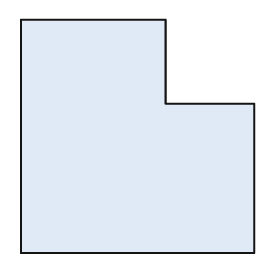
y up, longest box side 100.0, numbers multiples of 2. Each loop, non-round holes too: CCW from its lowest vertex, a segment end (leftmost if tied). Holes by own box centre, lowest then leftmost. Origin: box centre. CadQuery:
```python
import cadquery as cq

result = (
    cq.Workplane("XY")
    .moveTo(-50.0, -50.0)
    .lineTo(50.0, -50.0)
    .lineTo(50.0, 14.0)
    .lineTo(12.0, 14.0)
    .lineTo(12.0, 50.0)
    .lineTo(-50.0, 50.0)
    .close()
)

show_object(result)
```